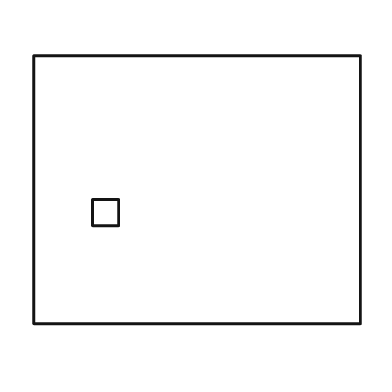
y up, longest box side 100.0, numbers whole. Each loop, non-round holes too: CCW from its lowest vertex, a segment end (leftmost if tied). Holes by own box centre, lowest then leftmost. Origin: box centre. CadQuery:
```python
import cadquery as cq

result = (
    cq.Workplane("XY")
    .moveTo(-50.0, -41.0)
    .lineTo(50.0, -41.0)
    .lineTo(50.0, 41.0)
    .lineTo(-50.0, 41.0)
    .close()
    .moveTo(-32.0, -11.0)
    .lineTo(-24.0, -11.0)
    .lineTo(-24.0, -3.0)
    .lineTo(-32.0, -3.0)
    .close()
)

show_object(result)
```